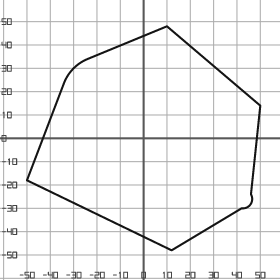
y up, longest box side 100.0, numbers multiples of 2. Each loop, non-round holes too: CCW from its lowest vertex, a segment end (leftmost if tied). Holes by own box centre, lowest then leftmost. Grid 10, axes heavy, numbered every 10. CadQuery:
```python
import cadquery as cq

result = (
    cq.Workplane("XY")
    .moveTo(12.0, -48.0)
    .lineTo(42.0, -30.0)
    .threePointArc((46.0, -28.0), (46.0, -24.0))
    .lineTo(50.0, 14.0)
    .lineTo(10.0, 48.0)
    .lineTo(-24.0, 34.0)
    .threePointArc((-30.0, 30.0), (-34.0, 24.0))
    .lineTo(-50.0, -18.0)
    .close()
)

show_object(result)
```